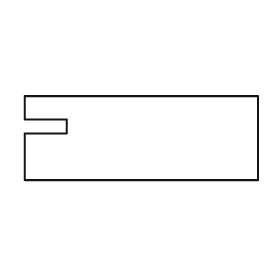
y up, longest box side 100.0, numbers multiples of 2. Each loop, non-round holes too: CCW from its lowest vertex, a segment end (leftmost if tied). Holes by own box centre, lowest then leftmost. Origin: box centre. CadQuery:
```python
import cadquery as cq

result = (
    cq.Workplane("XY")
    .moveTo(-50.0, -18.0)
    .lineTo(50.0, -18.0)
    .lineTo(50.0, 18.0)
    .lineTo(-50.0, 18.0)
    .lineTo(-50.0, 8.0)
    .lineTo(-32.0, 8.0)
    .lineTo(-32.0, 2.0)
    .lineTo(-50.0, 2.0)
    .close()
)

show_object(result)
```